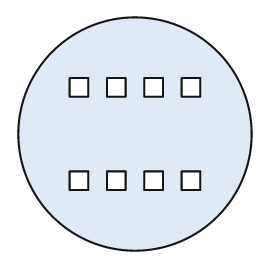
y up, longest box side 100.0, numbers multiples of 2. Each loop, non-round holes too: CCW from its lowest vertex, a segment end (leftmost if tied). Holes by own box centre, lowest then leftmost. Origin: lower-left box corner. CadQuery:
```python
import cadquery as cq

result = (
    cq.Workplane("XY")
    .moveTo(50.0, 50.0)
    .circle(50.0)
    .moveTo(22.0, 26.0)
    .lineTo(30.0, 26.0)
    .lineTo(30.0, 34.0)
    .lineTo(22.0, 34.0)
    .close()
    .moveTo(38.0, 26.0)
    .lineTo(46.0, 26.0)
    .lineTo(46.0, 34.0)
    .lineTo(38.0, 34.0)
    .close()
    .moveTo(54.0, 26.0)
    .lineTo(62.0, 26.0)
    .lineTo(62.0, 34.0)
    .lineTo(54.0, 34.0)
    .close()
    .moveTo(70.0, 26.0)
    .lineTo(78.0, 26.0)
    .lineTo(78.0, 34.0)
    .lineTo(70.0, 34.0)
    .close()
    .moveTo(22.0, 66.0)
    .lineTo(30.0, 66.0)
    .lineTo(30.0, 74.0)
    .lineTo(22.0, 74.0)
    .close()
    .moveTo(38.0, 66.0)
    .lineTo(46.0, 66.0)
    .lineTo(46.0, 74.0)
    .lineTo(38.0, 74.0)
    .close()
    .moveTo(54.0, 66.0)
    .lineTo(62.0, 66.0)
    .lineTo(62.0, 74.0)
    .lineTo(54.0, 74.0)
    .close()
    .moveTo(70.0, 66.0)
    .lineTo(78.0, 66.0)
    .lineTo(78.0, 74.0)
    .lineTo(70.0, 74.0)
    .close()
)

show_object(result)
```